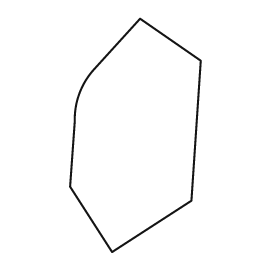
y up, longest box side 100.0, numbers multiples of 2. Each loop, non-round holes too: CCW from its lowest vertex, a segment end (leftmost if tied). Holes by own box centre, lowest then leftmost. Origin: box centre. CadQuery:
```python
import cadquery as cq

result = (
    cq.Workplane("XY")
    .moveTo(-10.0, -50.0)
    .lineTo(24.0, -28.0)
    .lineTo(28.0, 32.0)
    .lineTo(2.0, 50.0)
    .lineTo(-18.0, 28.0)
    .threePointArc((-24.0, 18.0), (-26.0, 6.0))
    .lineTo(-28.0, -22.0)
    .close()
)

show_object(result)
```